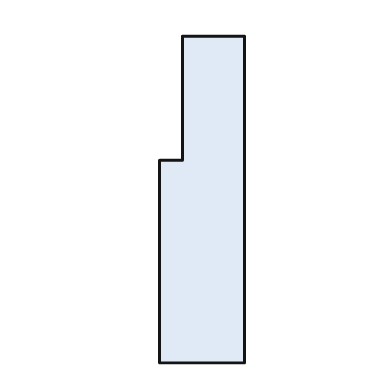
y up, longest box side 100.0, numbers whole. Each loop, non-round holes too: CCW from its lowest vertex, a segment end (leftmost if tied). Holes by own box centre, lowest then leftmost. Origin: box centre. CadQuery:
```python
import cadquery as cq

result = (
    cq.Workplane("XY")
    .moveTo(-13.0, -50.0)
    .lineTo(13.0, -50.0)
    .lineTo(13.0, 50.0)
    .lineTo(-6.0, 50.0)
    .lineTo(-6.0, 12.0)
    .lineTo(-13.0, 12.0)
    .close()
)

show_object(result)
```